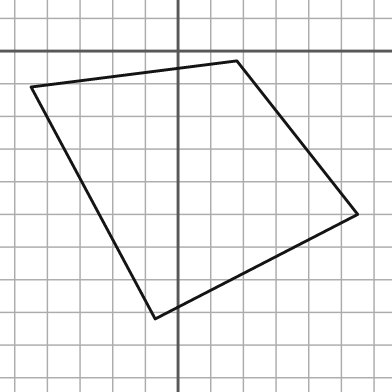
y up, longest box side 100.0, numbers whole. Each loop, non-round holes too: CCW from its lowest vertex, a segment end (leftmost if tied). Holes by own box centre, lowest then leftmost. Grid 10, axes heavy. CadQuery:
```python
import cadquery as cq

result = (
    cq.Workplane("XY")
    .moveTo(-7.0, -82.0)
    .lineTo(55.0, -50.0)
    .lineTo(18.0, -3.0)
    .lineTo(-45.0, -11.0)
    .close()
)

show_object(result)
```